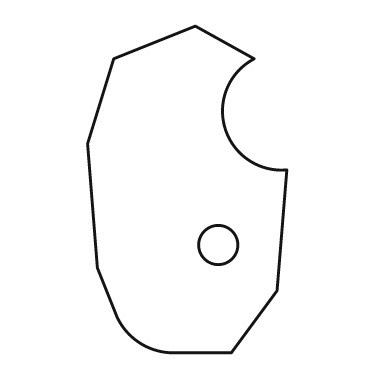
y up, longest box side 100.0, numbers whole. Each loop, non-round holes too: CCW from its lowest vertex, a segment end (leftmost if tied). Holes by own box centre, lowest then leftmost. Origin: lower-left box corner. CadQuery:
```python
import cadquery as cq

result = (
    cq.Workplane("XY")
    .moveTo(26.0, 0.0)
    .lineTo(44.0, 0.0)
    .lineTo(58.0, 19.0)
    .lineTo(61.0, 56.0)
    .threePointArc((42.0, 69.0), (51.0, 90.0))
    .lineTo(33.0, 100.0)
    .lineTo(8.0, 90.0)
    .lineTo(0.0, 64.0)
    .lineTo(3.0, 26.0)
    .lineTo(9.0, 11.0)
    .threePointArc((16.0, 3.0), (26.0, 0.0))
    .close()
    .moveTo(40.0, 33.0)
    .circle(6.0)
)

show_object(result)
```